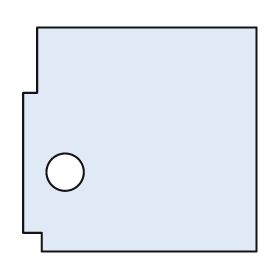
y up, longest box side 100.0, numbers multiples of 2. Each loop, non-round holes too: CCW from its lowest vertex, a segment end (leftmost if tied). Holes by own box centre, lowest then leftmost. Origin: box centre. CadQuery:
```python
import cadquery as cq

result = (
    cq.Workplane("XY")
    .moveTo(-42.0, -48.0)
    .lineTo(50.0, -48.0)
    .lineTo(50.0, 48.0)
    .lineTo(-44.0, 48.0)
    .lineTo(-44.0, 20.0)
    .lineTo(-50.0, 20.0)
    .lineTo(-50.0, -40.0)
    .lineTo(-42.0, -40.0)
    .close()
    .moveTo(-32.0, -14.0)
    .circle(8.0)
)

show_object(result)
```